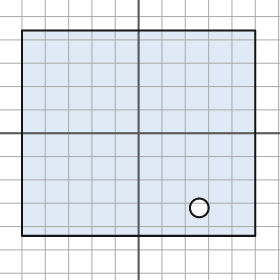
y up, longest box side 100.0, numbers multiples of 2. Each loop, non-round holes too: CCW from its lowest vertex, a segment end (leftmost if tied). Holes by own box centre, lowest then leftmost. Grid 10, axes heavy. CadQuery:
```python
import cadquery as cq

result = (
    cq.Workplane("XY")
    .moveTo(-50.0, -44.0)
    .lineTo(50.0, -44.0)
    .lineTo(50.0, 44.0)
    .lineTo(-50.0, 44.0)
    .close()
    .moveTo(26.0, -32.0)
    .circle(4.0)
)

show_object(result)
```